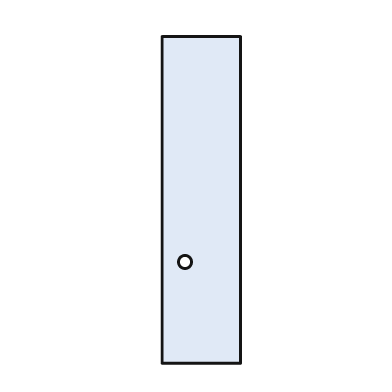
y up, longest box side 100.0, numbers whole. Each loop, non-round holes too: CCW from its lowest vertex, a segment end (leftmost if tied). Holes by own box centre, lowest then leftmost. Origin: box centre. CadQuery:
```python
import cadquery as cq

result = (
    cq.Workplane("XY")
    .moveTo(-12.0, -50.0)
    .lineTo(12.0, -50.0)
    .lineTo(12.0, 50.0)
    .lineTo(-12.0, 50.0)
    .close()
    .moveTo(-5.0, -19.0)
    .circle(2.0)
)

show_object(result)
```